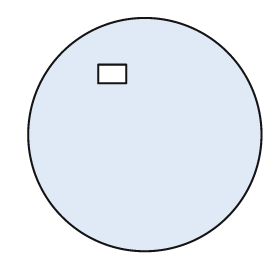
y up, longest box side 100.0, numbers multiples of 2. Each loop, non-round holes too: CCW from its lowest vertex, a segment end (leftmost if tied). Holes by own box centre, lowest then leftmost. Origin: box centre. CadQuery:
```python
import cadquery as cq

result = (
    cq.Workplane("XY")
    .moveTo(0.0, 0.0)
    .circle(50.0)
    .moveTo(-20.0, 22.0)
    .lineTo(-8.0, 22.0)
    .lineTo(-8.0, 30.0)
    .lineTo(-20.0, 30.0)
    .close()
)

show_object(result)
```